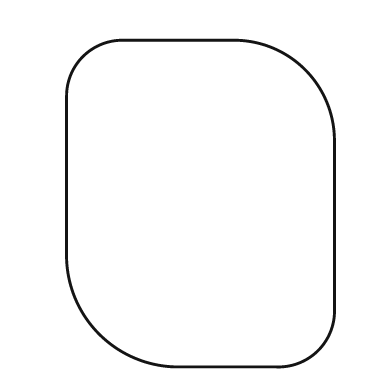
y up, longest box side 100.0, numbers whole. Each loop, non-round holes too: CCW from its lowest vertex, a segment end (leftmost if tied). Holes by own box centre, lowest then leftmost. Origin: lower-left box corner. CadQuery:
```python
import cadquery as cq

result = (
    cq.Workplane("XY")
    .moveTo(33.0, 0.0)
    .lineTo(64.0, 0.0)
    .threePointArc((77.0, 5.0), (82.0, 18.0))
    .lineTo(82.0, 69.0)
    .threePointArc((73.0, 91.0), (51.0, 100.0))
    .lineTo(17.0, 100.0)
    .threePointArc((5.0, 95.0), (0.0, 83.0))
    .lineTo(0.0, 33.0)
    .threePointArc((10.0, 10.0), (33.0, 0.0))
    .close()
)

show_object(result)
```